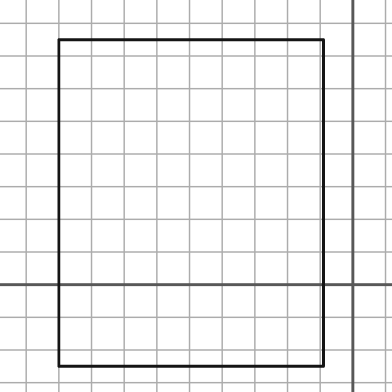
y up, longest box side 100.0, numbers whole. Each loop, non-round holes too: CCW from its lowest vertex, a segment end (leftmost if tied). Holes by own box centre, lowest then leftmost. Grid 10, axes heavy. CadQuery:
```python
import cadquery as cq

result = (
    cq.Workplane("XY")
    .moveTo(-90.0, -25.0)
    .lineTo(-9.0, -25.0)
    .lineTo(-9.0, 75.0)
    .lineTo(-90.0, 75.0)
    .close()
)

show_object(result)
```